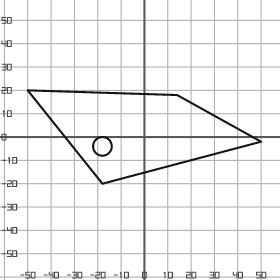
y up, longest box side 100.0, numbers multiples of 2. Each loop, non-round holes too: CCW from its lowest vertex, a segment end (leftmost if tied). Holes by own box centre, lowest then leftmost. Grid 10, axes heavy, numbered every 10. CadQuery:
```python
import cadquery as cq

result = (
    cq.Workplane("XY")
    .moveTo(-18.0, -20.0)
    .lineTo(50.0, -2.0)
    .lineTo(14.0, 18.0)
    .lineTo(-50.0, 20.0)
    .close()
    .moveTo(-18.0, -4.0)
    .circle(4.0)
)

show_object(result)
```